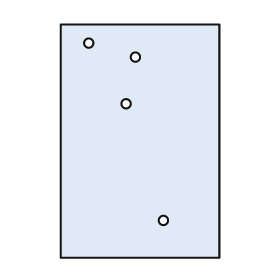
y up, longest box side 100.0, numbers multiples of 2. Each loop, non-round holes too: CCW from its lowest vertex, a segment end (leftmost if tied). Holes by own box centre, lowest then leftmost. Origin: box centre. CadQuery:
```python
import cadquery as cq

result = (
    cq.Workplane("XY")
    .moveTo(-34.0, -50.0)
    .lineTo(34.0, -50.0)
    .lineTo(34.0, 50.0)
    .lineTo(-34.0, 50.0)
    .close()
    .moveTo(10.0, -34.0)
    .circle(2.0)
    .moveTo(-6.0, 16.0)
    .circle(2.0)
    .moveTo(-2.0, 36.0)
    .circle(2.0)
    .moveTo(-22.0, 42.0)
    .circle(2.0)
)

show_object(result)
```